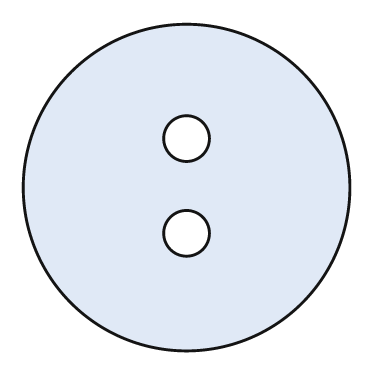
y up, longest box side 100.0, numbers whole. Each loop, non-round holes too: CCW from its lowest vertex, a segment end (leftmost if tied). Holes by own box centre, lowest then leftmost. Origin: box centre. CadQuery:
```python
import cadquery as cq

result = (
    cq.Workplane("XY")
    .moveTo(0.0, 0.0)
    .circle(50.0)
    .moveTo(0.0, -14.0)
    .circle(7.0)
    .moveTo(0.0, 15.0)
    .circle(7.0)
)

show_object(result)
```